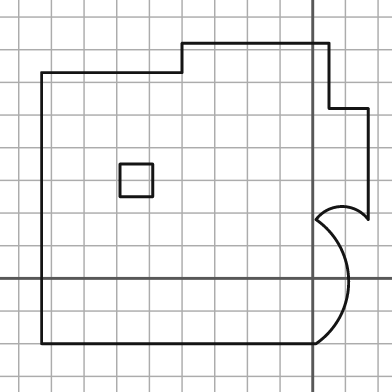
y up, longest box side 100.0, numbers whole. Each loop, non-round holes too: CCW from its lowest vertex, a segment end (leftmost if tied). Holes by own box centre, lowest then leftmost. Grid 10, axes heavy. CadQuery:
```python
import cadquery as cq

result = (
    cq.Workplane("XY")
    .moveTo(-83.0, -20.0)
    .lineTo(1.0, -20.0)
    .threePointArc((11.0, -1.0), (1.0, 18.0))
    .threePointArc((9.0, 22.0), (17.0, 18.0))
    .lineTo(17.0, 52.0)
    .lineTo(5.0, 52.0)
    .lineTo(5.0, 72.0)
    .lineTo(-40.0, 72.0)
    .lineTo(-40.0, 63.0)
    .lineTo(-83.0, 63.0)
    .close()
    .moveTo(-59.0, 25.0)
    .lineTo(-49.0, 25.0)
    .lineTo(-49.0, 35.0)
    .lineTo(-59.0, 35.0)
    .close()
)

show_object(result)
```